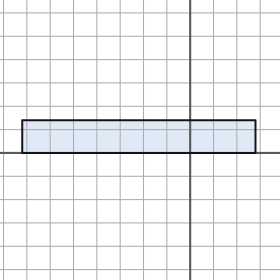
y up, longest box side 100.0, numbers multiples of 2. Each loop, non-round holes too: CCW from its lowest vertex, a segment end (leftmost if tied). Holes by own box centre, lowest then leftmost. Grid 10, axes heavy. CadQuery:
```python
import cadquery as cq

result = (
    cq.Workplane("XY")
    .moveTo(-72.0, 0.0)
    .lineTo(28.0, 0.0)
    .lineTo(28.0, 14.0)
    .lineTo(-72.0, 14.0)
    .close()
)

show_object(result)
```